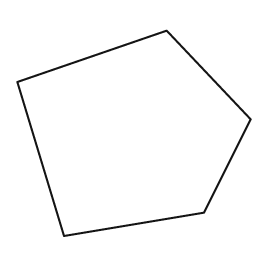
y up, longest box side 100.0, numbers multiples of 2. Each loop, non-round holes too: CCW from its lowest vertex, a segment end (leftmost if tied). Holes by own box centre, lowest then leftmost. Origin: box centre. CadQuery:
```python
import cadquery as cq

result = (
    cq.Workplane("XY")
    .moveTo(-30.0, -44.0)
    .lineTo(30.0, -34.0)
    .lineTo(50.0, 6.0)
    .lineTo(14.0, 44.0)
    .lineTo(-50.0, 22.0)
    .close()
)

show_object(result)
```